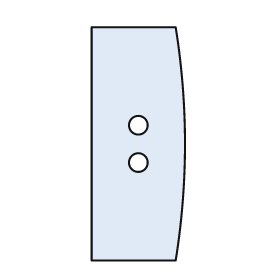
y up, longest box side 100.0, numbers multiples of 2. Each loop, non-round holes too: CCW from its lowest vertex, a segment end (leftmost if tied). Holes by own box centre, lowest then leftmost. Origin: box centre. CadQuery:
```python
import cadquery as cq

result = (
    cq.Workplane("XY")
    .moveTo(-20.0, -50.0)
    .lineTo(16.0, -50.0)
    .threePointArc((20.0, 0.0), (16.0, 50.0))
    .lineTo(-20.0, 50.0)
    .close()
    .moveTo(0.0, -8.0)
    .circle(4.0)
    .moveTo(0.0, 8.0)
    .circle(4.0)
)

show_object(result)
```